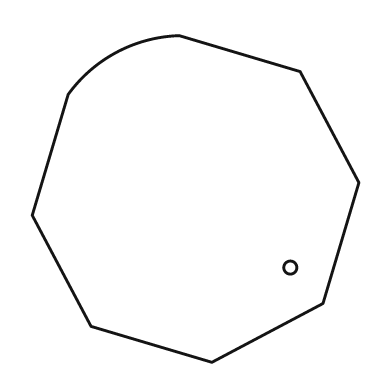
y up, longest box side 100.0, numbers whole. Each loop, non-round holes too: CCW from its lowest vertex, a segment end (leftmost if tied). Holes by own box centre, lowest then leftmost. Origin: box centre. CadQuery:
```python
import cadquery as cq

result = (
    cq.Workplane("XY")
    .moveTo(5.0, -50.0)
    .lineTo(39.0, -32.0)
    .lineTo(50.0, 5.0)
    .lineTo(32.0, 39.0)
    .lineTo(-5.0, 50.0)
    .threePointArc((-24.0, 45.0), (-39.0, 32.0))
    .lineTo(-50.0, -5.0)
    .lineTo(-32.0, -39.0)
    .close()
    .moveTo(29.0, -21.0)
    .circle(2.0)
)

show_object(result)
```